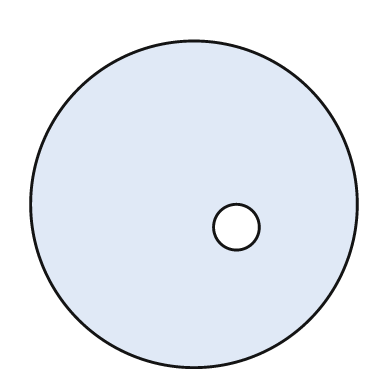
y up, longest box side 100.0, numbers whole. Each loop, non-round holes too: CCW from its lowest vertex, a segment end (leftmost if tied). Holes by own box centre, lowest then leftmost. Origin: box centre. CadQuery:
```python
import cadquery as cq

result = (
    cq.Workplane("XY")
    .moveTo(0.0, 0.0)
    .circle(50.0)
    .moveTo(13.0, -7.0)
    .circle(7.0)
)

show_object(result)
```